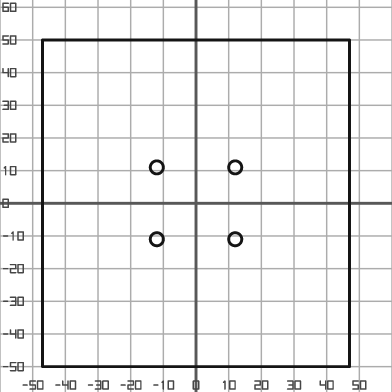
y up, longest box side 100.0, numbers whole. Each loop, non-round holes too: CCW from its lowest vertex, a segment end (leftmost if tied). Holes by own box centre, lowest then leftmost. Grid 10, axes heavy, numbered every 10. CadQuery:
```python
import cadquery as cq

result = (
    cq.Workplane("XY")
    .moveTo(-47.0, -50.0)
    .lineTo(47.0, -50.0)
    .lineTo(47.0, 50.0)
    .lineTo(-47.0, 50.0)
    .close()
    .moveTo(-12.0, -11.0)
    .circle(2.0)
    .moveTo(12.0, -11.0)
    .circle(2.0)
    .moveTo(-12.0, 11.0)
    .circle(2.0)
    .moveTo(12.0, 11.0)
    .circle(2.0)
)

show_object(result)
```